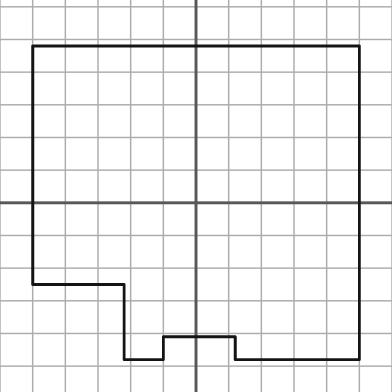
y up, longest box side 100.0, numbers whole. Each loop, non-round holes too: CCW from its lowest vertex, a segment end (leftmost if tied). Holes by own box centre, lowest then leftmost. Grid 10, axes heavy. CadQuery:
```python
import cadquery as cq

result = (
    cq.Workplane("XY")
    .moveTo(-22.0, -48.0)
    .lineTo(-10.0, -48.0)
    .lineTo(-10.0, -41.0)
    .lineTo(12.0, -41.0)
    .lineTo(12.0, -48.0)
    .lineTo(50.0, -48.0)
    .lineTo(50.0, 48.0)
    .lineTo(-50.0, 48.0)
    .lineTo(-50.0, -25.0)
    .lineTo(-22.0, -25.0)
    .close()
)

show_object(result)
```